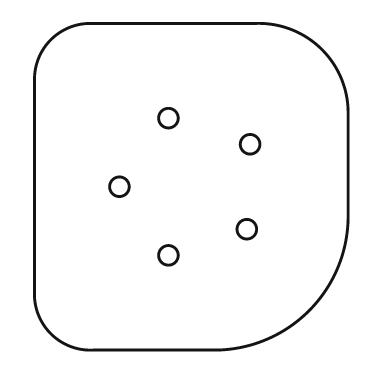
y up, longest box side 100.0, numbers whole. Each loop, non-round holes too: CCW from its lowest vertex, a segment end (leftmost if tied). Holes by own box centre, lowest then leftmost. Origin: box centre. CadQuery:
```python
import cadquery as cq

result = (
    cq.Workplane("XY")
    .moveTo(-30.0, -50.0)
    .lineTo(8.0, -50.0)
    .threePointArc((36.0, -38.0), (48.0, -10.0))
    .lineTo(48.0, 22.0)
    .threePointArc((40.0, 42.0), (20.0, 50.0))
    .lineTo(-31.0, 50.0)
    .threePointArc((-43.0, 45.0), (-48.0, 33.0))
    .lineTo(-48.0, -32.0)
    .threePointArc((-43.0, -45.0), (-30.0, -50.0))
    .close()
    .moveTo(-7.0, -21.0)
    .circle(3.0)
    .moveTo(17.0, -13.0)
    .circle(3.0)
    .moveTo(-22.0, 0.0)
    .circle(3.0)
    .moveTo(18.0, 13.0)
    .circle(3.0)
    .moveTo(-7.0, 21.0)
    .circle(3.0)
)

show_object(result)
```